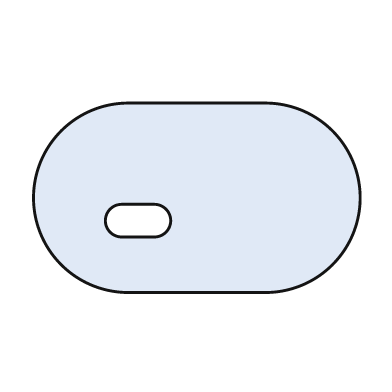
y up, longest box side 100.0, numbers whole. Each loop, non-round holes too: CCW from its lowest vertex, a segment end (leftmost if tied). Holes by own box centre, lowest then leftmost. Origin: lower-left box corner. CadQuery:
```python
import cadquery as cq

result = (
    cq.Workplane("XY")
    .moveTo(29.0, 0.0)
    .lineTo(71.0, 0.0)
    .threePointArc((100.0, 29.0), (71.0, 58.0))
    .lineTo(29.0, 58.0)
    .threePointArc((0.0, 29.0), (29.0, 0.0))
    .close()
    .moveTo(27.0, 17.0)
    .lineTo(37.0, 17.0)
    .threePointArc((42.0, 22.0), (37.0, 27.0))
    .lineTo(27.0, 27.0)
    .threePointArc((22.0, 22.0), (27.0, 17.0))
    .close()
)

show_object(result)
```